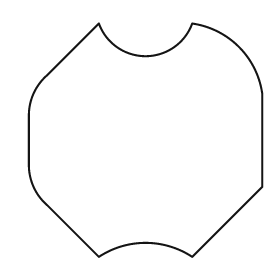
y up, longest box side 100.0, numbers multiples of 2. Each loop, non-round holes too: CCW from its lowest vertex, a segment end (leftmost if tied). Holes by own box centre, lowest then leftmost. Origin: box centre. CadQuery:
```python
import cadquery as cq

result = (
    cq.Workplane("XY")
    .moveTo(-20.0, -50.0)
    .threePointArc((0.0, -44.0), (20.0, -50.0))
    .lineTo(50.0, -20.0)
    .lineTo(50.0, 20.0)
    .threePointArc((40.0, 40.0), (20.0, 50.0))
    .threePointArc((0.0, 36.0), (-20.0, 50.0))
    .lineTo(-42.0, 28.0)
    .threePointArc((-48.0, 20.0), (-50.0, 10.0))
    .lineTo(-50.0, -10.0)
    .threePointArc((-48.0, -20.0), (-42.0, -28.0))
    .close()
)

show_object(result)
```